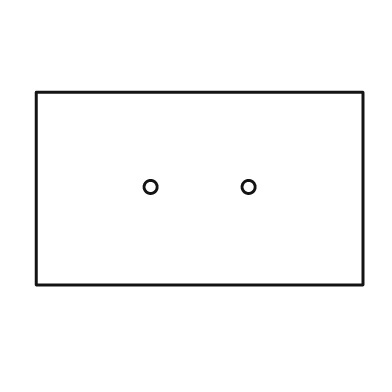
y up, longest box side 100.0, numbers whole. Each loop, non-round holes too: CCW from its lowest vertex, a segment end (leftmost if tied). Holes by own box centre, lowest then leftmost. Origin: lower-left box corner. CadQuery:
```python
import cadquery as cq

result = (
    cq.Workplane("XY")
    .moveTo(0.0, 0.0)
    .lineTo(100.0, 0.0)
    .lineTo(100.0, 59.0)
    .lineTo(0.0, 59.0)
    .close()
    .moveTo(35.0, 30.0)
    .circle(2.0)
    .moveTo(65.0, 30.0)
    .circle(2.0)
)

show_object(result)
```